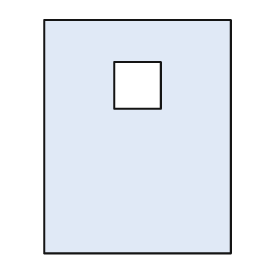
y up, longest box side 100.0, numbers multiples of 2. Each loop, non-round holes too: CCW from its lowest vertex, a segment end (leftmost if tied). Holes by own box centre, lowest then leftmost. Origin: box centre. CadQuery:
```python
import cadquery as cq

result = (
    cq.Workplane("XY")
    .moveTo(-40.0, -50.0)
    .lineTo(40.0, -50.0)
    .lineTo(40.0, 50.0)
    .lineTo(-40.0, 50.0)
    .close()
    .moveTo(-10.0, 12.0)
    .lineTo(10.0, 12.0)
    .lineTo(10.0, 32.0)
    .lineTo(-10.0, 32.0)
    .close()
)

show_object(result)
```